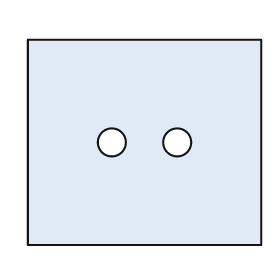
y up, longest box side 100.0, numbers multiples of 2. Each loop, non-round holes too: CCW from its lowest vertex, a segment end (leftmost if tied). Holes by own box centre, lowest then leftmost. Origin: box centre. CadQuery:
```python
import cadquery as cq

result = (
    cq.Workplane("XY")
    .moveTo(-50.0, -44.0)
    .lineTo(50.0, -44.0)
    .lineTo(50.0, 44.0)
    .lineTo(-50.0, 44.0)
    .close()
    .moveTo(-14.0, 0.0)
    .circle(6.0)
    .moveTo(14.0, 0.0)
    .circle(6.0)
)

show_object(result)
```